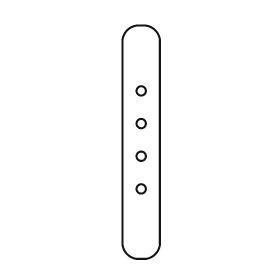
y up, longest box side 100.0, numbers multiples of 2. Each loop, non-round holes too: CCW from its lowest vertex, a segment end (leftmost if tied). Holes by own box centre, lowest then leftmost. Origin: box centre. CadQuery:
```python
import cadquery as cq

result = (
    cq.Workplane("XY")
    .moveTo(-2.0, -50.0)
    .lineTo(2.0, -50.0)
    .threePointArc((6.0, -48.0), (8.0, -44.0))
    .lineTo(8.0, 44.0)
    .threePointArc((6.0, 48.0), (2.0, 50.0))
    .lineTo(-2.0, 50.0)
    .threePointArc((-6.0, 48.0), (-8.0, 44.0))
    .lineTo(-8.0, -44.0)
    .threePointArc((-6.0, -48.0), (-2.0, -50.0))
    .close()
    .moveTo(0.0, -20.0)
    .circle(2.0)
    .moveTo(0.0, -6.0)
    .circle(2.0)
    .moveTo(0.0, 8.0)
    .circle(2.0)
    .moveTo(0.0, 22.0)
    .circle(2.0)
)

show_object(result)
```